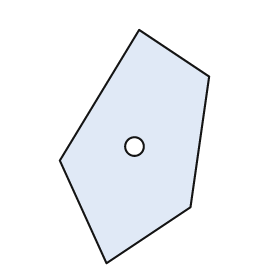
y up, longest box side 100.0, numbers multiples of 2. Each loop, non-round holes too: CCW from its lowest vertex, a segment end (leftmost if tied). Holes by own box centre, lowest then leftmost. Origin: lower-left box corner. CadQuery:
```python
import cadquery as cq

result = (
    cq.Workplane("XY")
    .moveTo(20.0, 0.0)
    .lineTo(56.0, 24.0)
    .lineTo(64.0, 80.0)
    .lineTo(34.0, 100.0)
    .lineTo(0.0, 44.0)
    .close()
    .moveTo(32.0, 50.0)
    .circle(4.0)
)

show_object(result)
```